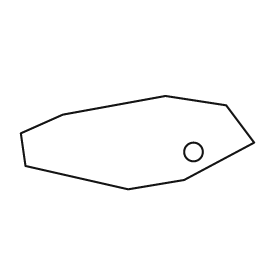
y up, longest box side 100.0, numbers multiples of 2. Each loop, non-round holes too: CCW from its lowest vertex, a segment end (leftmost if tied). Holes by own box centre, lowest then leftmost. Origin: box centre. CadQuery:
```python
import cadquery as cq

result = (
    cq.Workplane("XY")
    .moveTo(-4.0, -20.0)
    .lineTo(20.0, -16.0)
    .lineTo(50.0, 0.0)
    .lineTo(38.0, 16.0)
    .lineTo(12.0, 20.0)
    .lineTo(-32.0, 12.0)
    .lineTo(-50.0, 4.0)
    .lineTo(-48.0, -10.0)
    .close()
    .moveTo(24.0, -4.0)
    .circle(4.0)
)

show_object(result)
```